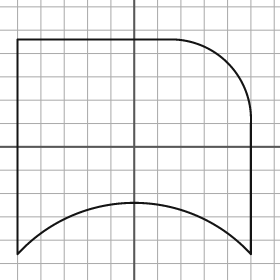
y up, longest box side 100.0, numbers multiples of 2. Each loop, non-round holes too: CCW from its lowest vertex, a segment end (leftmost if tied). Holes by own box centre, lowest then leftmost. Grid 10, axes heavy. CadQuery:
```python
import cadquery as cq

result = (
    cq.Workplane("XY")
    .moveTo(-50.0, -46.0)
    .threePointArc((0.0, -24.0), (50.0, -46.0))
    .lineTo(50.0, 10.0)
    .threePointArc((40.0, 36.0), (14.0, 46.0))
    .lineTo(-50.0, 46.0)
    .close()
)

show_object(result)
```